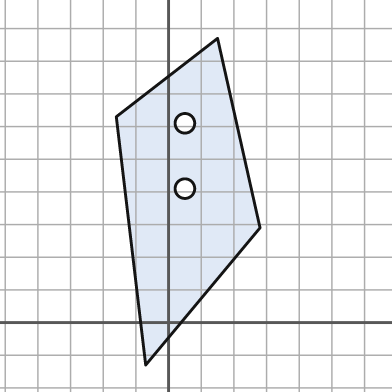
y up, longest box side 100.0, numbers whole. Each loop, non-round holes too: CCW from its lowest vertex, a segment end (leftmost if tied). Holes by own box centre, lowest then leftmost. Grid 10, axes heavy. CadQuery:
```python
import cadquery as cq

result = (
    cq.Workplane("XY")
    .moveTo(-7.0, -13.0)
    .lineTo(28.0, 29.0)
    .lineTo(15.0, 87.0)
    .lineTo(-16.0, 63.0)
    .close()
    .moveTo(5.0, 41.0)
    .circle(3.0)
    .moveTo(5.0, 61.0)
    .circle(3.0)
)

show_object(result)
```